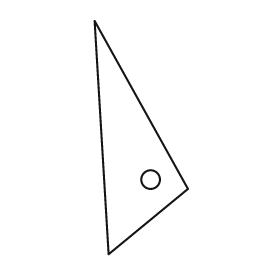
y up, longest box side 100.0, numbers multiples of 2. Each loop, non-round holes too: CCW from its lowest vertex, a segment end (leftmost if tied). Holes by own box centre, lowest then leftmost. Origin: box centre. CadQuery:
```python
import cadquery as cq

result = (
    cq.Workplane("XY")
    .moveTo(-14.0, -50.0)
    .lineTo(20.0, -22.0)
    .lineTo(-20.0, 50.0)
    .close()
    .moveTo(4.0, -18.0)
    .circle(4.0)
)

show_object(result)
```